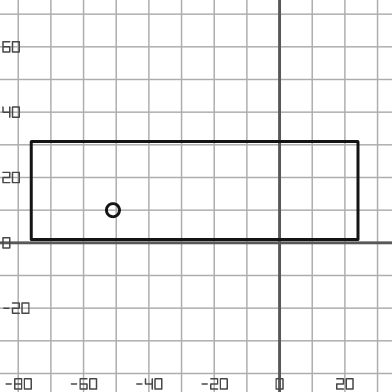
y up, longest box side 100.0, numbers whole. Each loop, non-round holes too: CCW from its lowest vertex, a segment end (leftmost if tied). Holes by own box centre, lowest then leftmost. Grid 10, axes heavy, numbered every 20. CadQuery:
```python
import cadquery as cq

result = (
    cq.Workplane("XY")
    .moveTo(-76.0, 1.0)
    .lineTo(24.0, 1.0)
    .lineTo(24.0, 31.0)
    .lineTo(-76.0, 31.0)
    .close()
    .moveTo(-51.0, 10.0)
    .circle(2.0)
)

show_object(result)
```